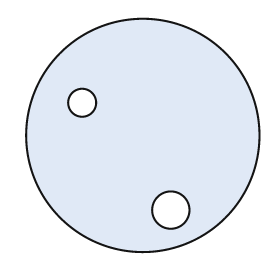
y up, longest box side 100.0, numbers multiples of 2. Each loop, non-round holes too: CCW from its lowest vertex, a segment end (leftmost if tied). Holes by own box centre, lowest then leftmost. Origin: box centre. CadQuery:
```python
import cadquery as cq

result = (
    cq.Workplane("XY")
    .moveTo(0.0, 0.0)
    .circle(50.0)
    .moveTo(12.0, -32.0)
    .circle(8.0)
    .moveTo(-26.0, 14.0)
    .circle(6.0)
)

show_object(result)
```